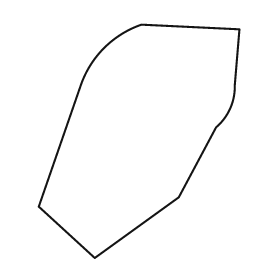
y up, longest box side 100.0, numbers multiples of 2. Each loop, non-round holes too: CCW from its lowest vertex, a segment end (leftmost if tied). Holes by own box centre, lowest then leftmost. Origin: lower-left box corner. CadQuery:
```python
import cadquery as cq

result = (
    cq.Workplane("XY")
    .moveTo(24.0, 0.0)
    .lineTo(60.0, 26.0)
    .lineTo(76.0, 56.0)
    .threePointArc((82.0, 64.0), (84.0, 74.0))
    .lineTo(86.0, 98.0)
    .lineTo(44.0, 100.0)
    .threePointArc((28.0, 90.0), (18.0, 74.0))
    .lineTo(0.0, 22.0)
    .close()
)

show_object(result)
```